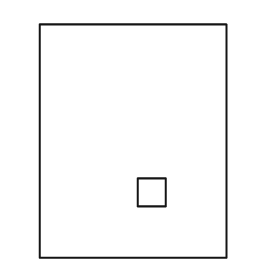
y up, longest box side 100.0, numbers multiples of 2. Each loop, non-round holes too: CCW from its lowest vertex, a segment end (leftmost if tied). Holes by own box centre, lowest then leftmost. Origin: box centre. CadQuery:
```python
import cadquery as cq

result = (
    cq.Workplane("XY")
    .moveTo(-40.0, -50.0)
    .lineTo(40.0, -50.0)
    .lineTo(40.0, 50.0)
    .lineTo(-40.0, 50.0)
    .close()
    .moveTo(2.0, -28.0)
    .lineTo(14.0, -28.0)
    .lineTo(14.0, -16.0)
    .lineTo(2.0, -16.0)
    .close()
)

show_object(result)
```